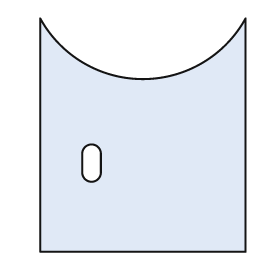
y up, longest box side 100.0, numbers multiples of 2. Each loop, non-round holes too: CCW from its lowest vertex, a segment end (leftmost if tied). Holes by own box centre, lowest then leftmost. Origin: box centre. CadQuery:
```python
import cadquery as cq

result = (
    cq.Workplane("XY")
    .moveTo(-44.0, -50.0)
    .lineTo(44.0, -50.0)
    .lineTo(44.0, 50.0)
    .threePointArc((0.0, 24.0), (-44.0, 50.0))
    .close()
    .moveTo(-26.0, -16.0)
    .threePointArc((-22.0, -20.0), (-18.0, -16.0))
    .lineTo(-18.0, -8.0)
    .threePointArc((-22.0, -4.0), (-26.0, -8.0))
    .close()
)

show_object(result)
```